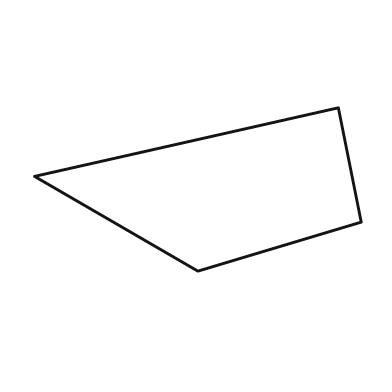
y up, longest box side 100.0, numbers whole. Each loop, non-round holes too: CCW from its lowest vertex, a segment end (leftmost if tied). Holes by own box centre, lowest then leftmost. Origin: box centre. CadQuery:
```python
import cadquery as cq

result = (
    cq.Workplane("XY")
    .moveTo(0.0, -25.0)
    .lineTo(50.0, -10.0)
    .lineTo(43.0, 25.0)
    .lineTo(-50.0, 4.0)
    .close()
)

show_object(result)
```